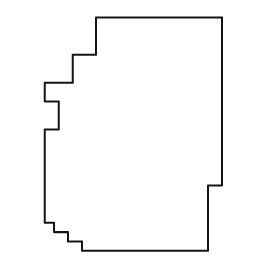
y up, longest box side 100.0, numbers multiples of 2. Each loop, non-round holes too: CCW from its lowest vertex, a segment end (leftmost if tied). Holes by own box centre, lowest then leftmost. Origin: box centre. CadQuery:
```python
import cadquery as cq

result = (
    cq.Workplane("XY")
    .moveTo(-22.0, -50.0)
    .lineTo(32.0, -50.0)
    .lineTo(32.0, -22.0)
    .lineTo(38.0, -22.0)
    .lineTo(38.0, 50.0)
    .lineTo(-16.0, 50.0)
    .lineTo(-16.0, 34.0)
    .lineTo(-26.0, 34.0)
    .lineTo(-26.0, 22.0)
    .lineTo(-38.0, 22.0)
    .lineTo(-38.0, 14.0)
    .lineTo(-32.0, 14.0)
    .lineTo(-32.0, 2.0)
    .lineTo(-38.0, 2.0)
    .lineTo(-38.0, -38.0)
    .lineTo(-34.0, -38.0)
    .lineTo(-34.0, -42.0)
    .lineTo(-28.0, -42.0)
    .lineTo(-28.0, -46.0)
    .lineTo(-22.0, -46.0)
    .close()
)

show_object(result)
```